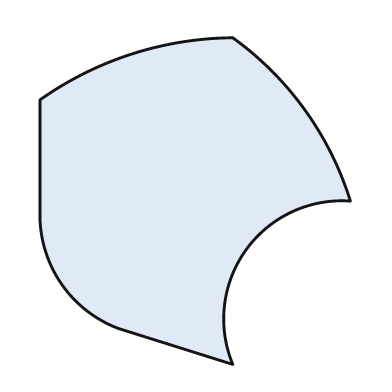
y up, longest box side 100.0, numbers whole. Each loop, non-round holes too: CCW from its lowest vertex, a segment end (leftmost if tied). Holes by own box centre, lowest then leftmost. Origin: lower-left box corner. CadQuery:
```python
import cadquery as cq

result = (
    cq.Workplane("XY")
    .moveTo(59.0, 0.0)
    .threePointArc((63.0, 35.0), (95.0, 50.0))
    .threePointArc((81.0, 78.0), (59.0, 100.0))
    .threePointArc((28.0, 95.0), (0.0, 81.0))
    .lineTo(0.0, 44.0)
    .threePointArc((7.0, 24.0), (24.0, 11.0))
    .close()
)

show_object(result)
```